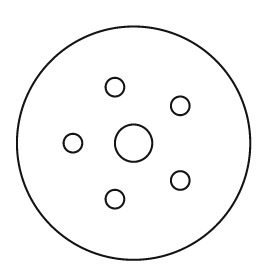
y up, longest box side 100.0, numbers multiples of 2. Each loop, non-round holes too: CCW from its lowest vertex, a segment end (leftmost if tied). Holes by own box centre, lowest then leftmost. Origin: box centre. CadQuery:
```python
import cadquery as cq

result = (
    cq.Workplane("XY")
    .moveTo(0.0, 0.0)
    .circle(50.0)
    .moveTo(-8.0, -24.0)
    .circle(4.0)
    .moveTo(20.0, -16.0)
    .circle(4.0)
    .moveTo(-26.0, 0.0)
    .circle(4.0)
    .moveTo(0.0, 0.0)
    .circle(8.0)
    .moveTo(20.0, 16.0)
    .circle(4.0)
    .moveTo(-8.0, 24.0)
    .circle(4.0)
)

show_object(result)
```